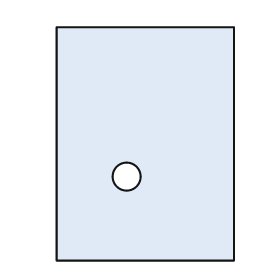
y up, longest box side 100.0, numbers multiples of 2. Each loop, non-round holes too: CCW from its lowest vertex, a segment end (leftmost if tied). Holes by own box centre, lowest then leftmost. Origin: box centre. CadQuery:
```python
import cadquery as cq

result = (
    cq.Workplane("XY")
    .moveTo(-38.0, -50.0)
    .lineTo(38.0, -50.0)
    .lineTo(38.0, 50.0)
    .lineTo(-38.0, 50.0)
    .close()
    .moveTo(-8.0, -14.0)
    .circle(6.0)
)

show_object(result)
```